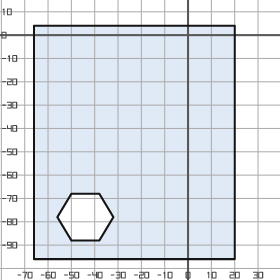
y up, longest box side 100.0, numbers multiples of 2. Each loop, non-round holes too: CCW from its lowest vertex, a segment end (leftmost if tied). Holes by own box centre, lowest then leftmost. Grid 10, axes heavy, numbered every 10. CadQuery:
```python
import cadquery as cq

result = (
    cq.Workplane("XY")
    .moveTo(-66.0, -96.0)
    .lineTo(20.0, -96.0)
    .lineTo(20.0, 4.0)
    .lineTo(-66.0, 4.0)
    .close()
    .moveTo(-50.0, -88.0)
    .lineTo(-38.0, -88.0)
    .lineTo(-32.0, -78.0)
    .lineTo(-38.0, -68.0)
    .lineTo(-50.0, -68.0)
    .lineTo(-56.0, -78.0)
    .close()
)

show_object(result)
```